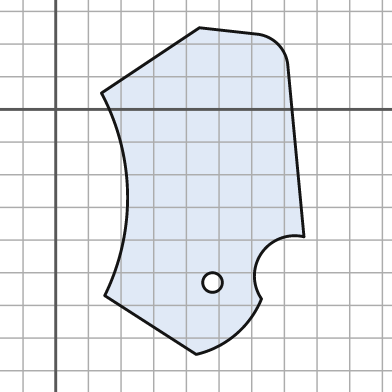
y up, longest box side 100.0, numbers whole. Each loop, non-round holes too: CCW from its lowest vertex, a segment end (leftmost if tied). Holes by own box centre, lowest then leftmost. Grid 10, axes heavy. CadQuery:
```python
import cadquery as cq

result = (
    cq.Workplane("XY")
    .moveTo(43.0, -75.0)
    .threePointArc((55.0, -69.0), (63.0, -58.0))
    .threePointArc((63.0, -44.0), (76.0, -39.0))
    .lineTo(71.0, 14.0)
    .threePointArc((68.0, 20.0), (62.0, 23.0))
    .lineTo(44.0, 25.0)
    .lineTo(14.0, 5.0)
    .threePointArc((22.0, -26.0), (15.0, -57.0))
    .close()
    .moveTo(48.0, -53.0)
    .circle(3.0)
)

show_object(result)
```